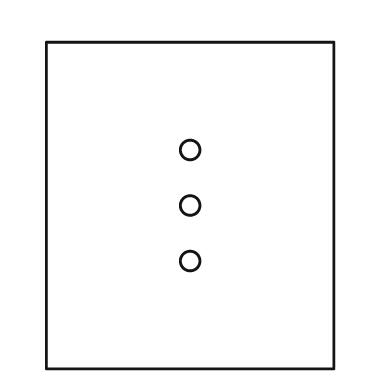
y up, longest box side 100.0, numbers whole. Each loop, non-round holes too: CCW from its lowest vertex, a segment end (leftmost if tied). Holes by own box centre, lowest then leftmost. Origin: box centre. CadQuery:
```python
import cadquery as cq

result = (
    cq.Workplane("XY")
    .moveTo(-44.0, -50.0)
    .lineTo(44.0, -50.0)
    .lineTo(44.0, 50.0)
    .lineTo(-44.0, 50.0)
    .close()
    .moveTo(0.0, -17.0)
    .circle(3.0)
    .moveTo(0.0, 0.0)
    .circle(3.0)
    .moveTo(0.0, 17.0)
    .circle(3.0)
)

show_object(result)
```